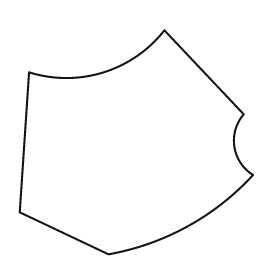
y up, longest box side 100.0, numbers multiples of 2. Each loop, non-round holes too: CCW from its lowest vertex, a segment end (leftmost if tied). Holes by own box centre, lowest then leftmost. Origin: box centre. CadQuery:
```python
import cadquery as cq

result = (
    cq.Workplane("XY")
    .moveTo(-12.0, -48.0)
    .threePointArc((22.0, -36.0), (50.0, -14.0))
    .threePointArc((42.0, -2.0), (46.0, 12.0))
    .lineTo(12.0, 48.0)
    .threePointArc((-14.0, 30.0), (-46.0, 30.0))
    .lineTo(-50.0, -30.0)
    .close()
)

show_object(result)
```